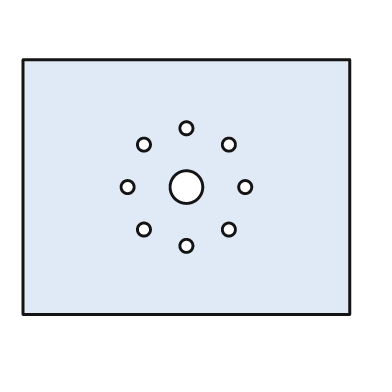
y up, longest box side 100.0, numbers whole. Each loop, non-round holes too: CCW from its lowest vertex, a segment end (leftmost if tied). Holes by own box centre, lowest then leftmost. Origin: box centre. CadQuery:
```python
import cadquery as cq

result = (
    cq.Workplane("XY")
    .moveTo(-50.0, -39.0)
    .lineTo(50.0, -39.0)
    .lineTo(50.0, 39.0)
    .lineTo(-50.0, 39.0)
    .close()
    .moveTo(0.0, -18.0)
    .circle(2.0)
    .moveTo(-13.0, -13.0)
    .circle(2.0)
    .moveTo(13.0, -13.0)
    .circle(2.0)
    .moveTo(-18.0, 0.0)
    .circle(2.0)
    .moveTo(0.0, 0.0)
    .circle(5.0)
    .moveTo(18.0, 0.0)
    .circle(2.0)
    .moveTo(-13.0, 13.0)
    .circle(2.0)
    .moveTo(13.0, 13.0)
    .circle(2.0)
    .moveTo(0.0, 18.0)
    .circle(2.0)
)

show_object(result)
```